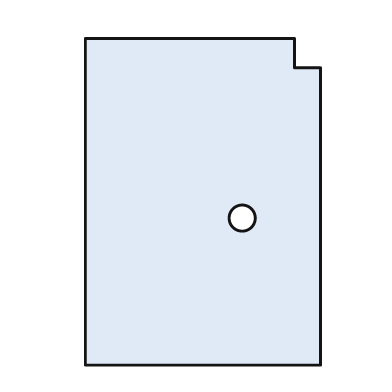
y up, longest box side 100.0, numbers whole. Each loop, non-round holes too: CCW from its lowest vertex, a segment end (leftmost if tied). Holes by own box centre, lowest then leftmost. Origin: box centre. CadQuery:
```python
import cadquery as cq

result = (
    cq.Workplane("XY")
    .moveTo(-36.0, -50.0)
    .lineTo(36.0, -50.0)
    .lineTo(36.0, 41.0)
    .lineTo(28.0, 41.0)
    .lineTo(28.0, 50.0)
    .lineTo(-36.0, 50.0)
    .close()
    .moveTo(12.0, -5.0)
    .circle(4.0)
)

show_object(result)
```